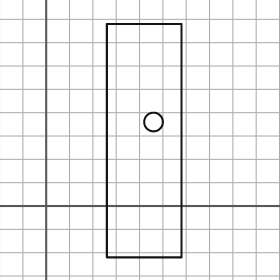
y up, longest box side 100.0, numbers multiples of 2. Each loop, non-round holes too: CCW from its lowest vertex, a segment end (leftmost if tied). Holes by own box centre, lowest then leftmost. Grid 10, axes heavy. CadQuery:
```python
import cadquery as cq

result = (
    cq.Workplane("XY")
    .moveTo(26.0, -22.0)
    .lineTo(58.0, -22.0)
    .lineTo(58.0, 78.0)
    .lineTo(26.0, 78.0)
    .close()
    .moveTo(46.0, 36.0)
    .circle(4.0)
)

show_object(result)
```